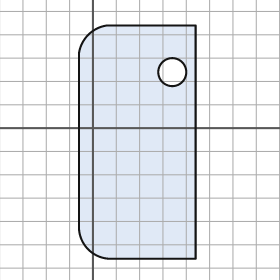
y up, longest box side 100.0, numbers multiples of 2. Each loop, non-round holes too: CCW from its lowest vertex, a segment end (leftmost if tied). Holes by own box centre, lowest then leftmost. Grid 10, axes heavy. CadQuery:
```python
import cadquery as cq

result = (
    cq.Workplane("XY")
    .moveTo(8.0, -56.0)
    .lineTo(44.0, -56.0)
    .lineTo(44.0, 44.0)
    .lineTo(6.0, 44.0)
    .threePointArc((-2.0, 40.0), (-6.0, 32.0))
    .lineTo(-6.0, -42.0)
    .threePointArc((-2.0, -52.0), (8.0, -56.0))
    .close()
    .moveTo(34.0, 24.0)
    .circle(6.0)
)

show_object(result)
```